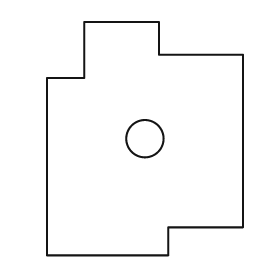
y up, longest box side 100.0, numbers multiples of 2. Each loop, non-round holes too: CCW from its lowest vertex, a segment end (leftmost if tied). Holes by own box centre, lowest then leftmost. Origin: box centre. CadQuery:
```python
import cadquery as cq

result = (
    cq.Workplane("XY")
    .moveTo(-42.0, -50.0)
    .lineTo(10.0, -50.0)
    .lineTo(10.0, -38.0)
    .lineTo(42.0, -38.0)
    .lineTo(42.0, 36.0)
    .lineTo(6.0, 36.0)
    .lineTo(6.0, 50.0)
    .lineTo(-26.0, 50.0)
    .lineTo(-26.0, 26.0)
    .lineTo(-42.0, 26.0)
    .close()
    .moveTo(0.0, 0.0)
    .circle(8.0)
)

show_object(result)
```